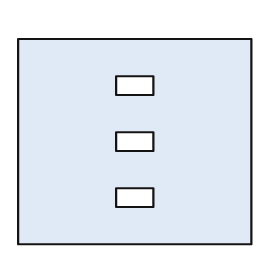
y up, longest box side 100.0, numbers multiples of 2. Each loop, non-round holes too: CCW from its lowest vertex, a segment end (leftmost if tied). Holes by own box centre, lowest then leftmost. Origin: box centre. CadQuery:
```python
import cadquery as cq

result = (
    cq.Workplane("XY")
    .moveTo(-50.0, -44.0)
    .lineTo(50.0, -44.0)
    .lineTo(50.0, 44.0)
    .lineTo(-50.0, 44.0)
    .close()
    .moveTo(-8.0, -28.0)
    .lineTo(8.0, -28.0)
    .lineTo(8.0, -20.0)
    .lineTo(-8.0, -20.0)
    .close()
    .moveTo(-8.0, -4.0)
    .lineTo(8.0, -4.0)
    .lineTo(8.0, 4.0)
    .lineTo(-8.0, 4.0)
    .close()
    .moveTo(-8.0, 20.0)
    .lineTo(8.0, 20.0)
    .lineTo(8.0, 28.0)
    .lineTo(-8.0, 28.0)
    .close()
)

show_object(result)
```